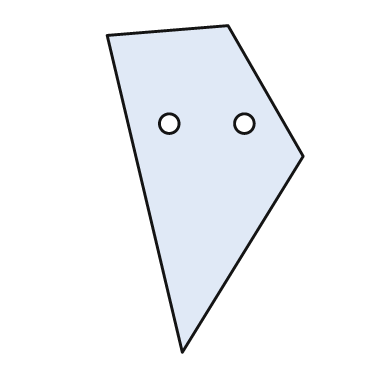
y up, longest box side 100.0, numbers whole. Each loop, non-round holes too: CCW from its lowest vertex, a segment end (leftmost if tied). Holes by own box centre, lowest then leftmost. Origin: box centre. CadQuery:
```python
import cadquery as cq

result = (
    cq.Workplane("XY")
    .moveTo(-7.0, -50.0)
    .lineTo(30.0, 10.0)
    .lineTo(7.0, 50.0)
    .lineTo(-30.0, 47.0)
    .close()
    .moveTo(-11.0, 20.0)
    .circle(3.0)
    .moveTo(12.0, 20.0)
    .circle(3.0)
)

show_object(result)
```